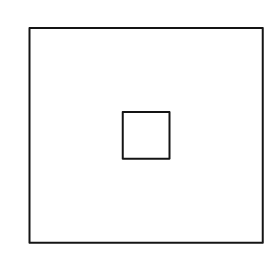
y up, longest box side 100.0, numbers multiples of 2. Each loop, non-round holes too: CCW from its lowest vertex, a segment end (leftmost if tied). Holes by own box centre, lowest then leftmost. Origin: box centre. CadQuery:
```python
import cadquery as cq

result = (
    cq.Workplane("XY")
    .moveTo(-50.0, -46.0)
    .lineTo(50.0, -46.0)
    .lineTo(50.0, 46.0)
    .lineTo(-50.0, 46.0)
    .close()
    .moveTo(-10.0, -10.0)
    .lineTo(10.0, -10.0)
    .lineTo(10.0, 10.0)
    .lineTo(-10.0, 10.0)
    .close()
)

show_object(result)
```